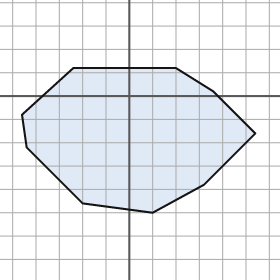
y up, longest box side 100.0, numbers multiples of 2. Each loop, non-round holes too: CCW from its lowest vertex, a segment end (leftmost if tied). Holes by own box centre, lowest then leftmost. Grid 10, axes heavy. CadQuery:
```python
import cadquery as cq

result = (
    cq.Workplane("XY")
    .moveTo(10.0, -50.0)
    .lineTo(32.0, -38.0)
    .lineTo(54.0, -16.0)
    .lineTo(36.0, 2.0)
    .lineTo(20.0, 12.0)
    .lineTo(-24.0, 12.0)
    .lineTo(-46.0, -8.0)
    .lineTo(-44.0, -22.0)
    .lineTo(-20.0, -46.0)
    .close()
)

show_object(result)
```